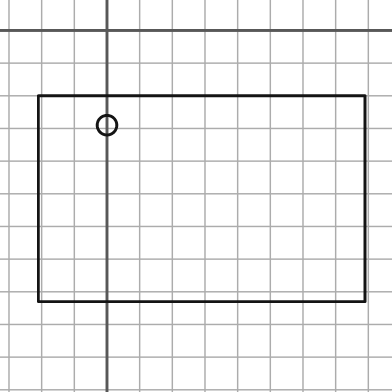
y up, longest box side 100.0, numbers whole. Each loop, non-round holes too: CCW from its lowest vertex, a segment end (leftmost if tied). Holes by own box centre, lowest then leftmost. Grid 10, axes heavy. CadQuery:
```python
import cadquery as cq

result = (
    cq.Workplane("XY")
    .moveTo(-21.0, -83.0)
    .lineTo(79.0, -83.0)
    .lineTo(79.0, -20.0)
    .lineTo(-21.0, -20.0)
    .close()
    .moveTo(0.0, -29.0)
    .circle(3.0)
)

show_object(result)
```